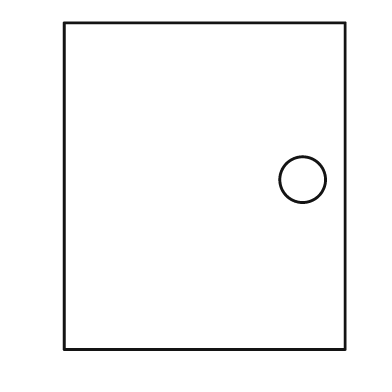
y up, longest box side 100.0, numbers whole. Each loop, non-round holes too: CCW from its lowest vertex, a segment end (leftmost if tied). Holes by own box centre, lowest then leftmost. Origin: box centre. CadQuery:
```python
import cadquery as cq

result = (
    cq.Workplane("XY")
    .moveTo(-43.0, -50.0)
    .lineTo(43.0, -50.0)
    .lineTo(43.0, 50.0)
    .lineTo(-43.0, 50.0)
    .close()
    .moveTo(30.0, 2.0)
    .circle(7.0)
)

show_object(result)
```